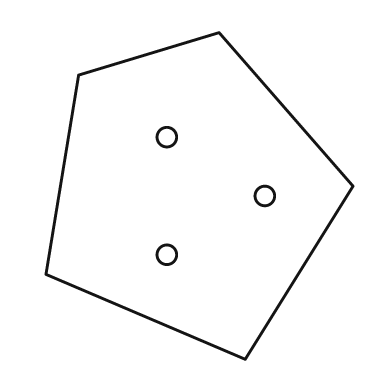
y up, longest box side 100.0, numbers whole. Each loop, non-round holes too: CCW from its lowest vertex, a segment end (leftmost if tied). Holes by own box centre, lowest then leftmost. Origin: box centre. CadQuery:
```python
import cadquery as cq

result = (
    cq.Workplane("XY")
    .moveTo(14.0, -50.0)
    .lineTo(47.0, 3.0)
    .lineTo(6.0, 50.0)
    .lineTo(-37.0, 37.0)
    .lineTo(-47.0, -24.0)
    .close()
    .moveTo(-10.0, -18.0)
    .circle(3.0)
    .moveTo(20.0, 0.0)
    .circle(3.0)
    .moveTo(-10.0, 18.0)
    .circle(3.0)
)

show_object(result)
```